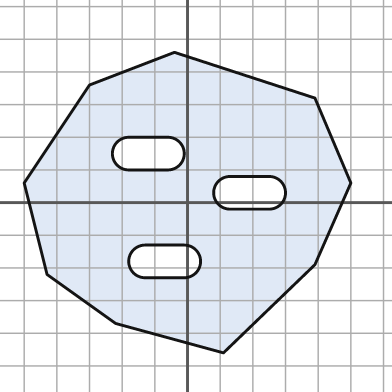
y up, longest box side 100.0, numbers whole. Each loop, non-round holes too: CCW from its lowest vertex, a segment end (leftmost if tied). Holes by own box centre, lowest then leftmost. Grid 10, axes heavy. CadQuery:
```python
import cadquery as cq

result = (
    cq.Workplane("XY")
    .moveTo(11.0, -46.0)
    .lineTo(39.0, -19.0)
    .lineTo(50.0, 6.0)
    .lineTo(39.0, 32.0)
    .lineTo(-4.0, 46.0)
    .lineTo(-30.0, 36.0)
    .lineTo(-50.0, 6.0)
    .lineTo(-43.0, -22.0)
    .lineTo(-22.0, -37.0)
    .close()
    .moveTo(-13.0, -23.0)
    .lineTo(-1.0, -23.0)
    .threePointArc((4.0, -18.0), (-1.0, -13.0))
    .lineTo(-13.0, -13.0)
    .threePointArc((-18.0, -18.0), (-13.0, -23.0))
    .close()
    .moveTo(13.0, -2.0)
    .lineTo(25.0, -2.0)
    .threePointArc((30.0, 3.0), (25.0, 8.0))
    .lineTo(13.0, 8.0)
    .threePointArc((8.0, 3.0), (13.0, -2.0))
    .close()
    .moveTo(-18.0, 10.0)
    .lineTo(-6.0, 10.0)
    .threePointArc((-1.0, 15.0), (-6.0, 20.0))
    .lineTo(-18.0, 20.0)
    .threePointArc((-23.0, 15.0), (-18.0, 10.0))
    .close()
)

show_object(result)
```